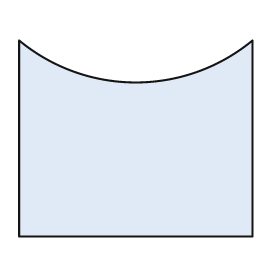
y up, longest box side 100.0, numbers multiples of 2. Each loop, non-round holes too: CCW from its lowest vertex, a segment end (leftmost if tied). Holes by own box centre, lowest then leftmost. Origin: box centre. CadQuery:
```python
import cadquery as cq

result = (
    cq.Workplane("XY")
    .moveTo(-50.0, -42.0)
    .lineTo(50.0, -42.0)
    .lineTo(50.0, 42.0)
    .threePointArc((0.0, 24.0), (-50.0, 42.0))
    .close()
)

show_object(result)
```